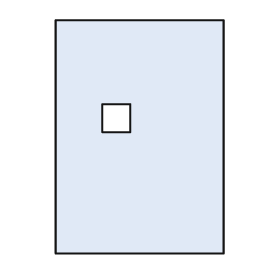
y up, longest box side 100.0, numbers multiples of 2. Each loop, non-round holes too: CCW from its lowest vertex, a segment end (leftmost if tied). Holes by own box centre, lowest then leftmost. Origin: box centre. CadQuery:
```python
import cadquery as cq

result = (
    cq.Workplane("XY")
    .moveTo(-36.0, -50.0)
    .lineTo(36.0, -50.0)
    .lineTo(36.0, 50.0)
    .lineTo(-36.0, 50.0)
    .close()
    .moveTo(-16.0, 2.0)
    .lineTo(-4.0, 2.0)
    .lineTo(-4.0, 14.0)
    .lineTo(-16.0, 14.0)
    .close()
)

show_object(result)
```